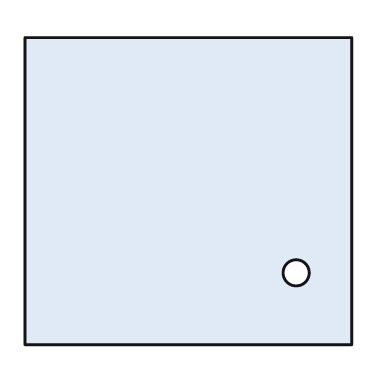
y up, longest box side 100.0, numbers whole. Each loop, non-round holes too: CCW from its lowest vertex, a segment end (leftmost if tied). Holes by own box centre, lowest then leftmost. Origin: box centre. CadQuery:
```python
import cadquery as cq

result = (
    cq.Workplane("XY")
    .moveTo(-50.0, -47.0)
    .lineTo(50.0, -47.0)
    .lineTo(50.0, 47.0)
    .lineTo(-50.0, 47.0)
    .close()
    .moveTo(33.0, -25.0)
    .circle(4.0)
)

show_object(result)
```